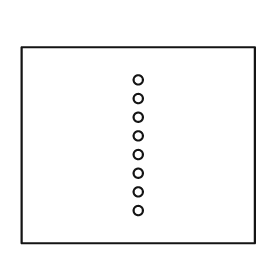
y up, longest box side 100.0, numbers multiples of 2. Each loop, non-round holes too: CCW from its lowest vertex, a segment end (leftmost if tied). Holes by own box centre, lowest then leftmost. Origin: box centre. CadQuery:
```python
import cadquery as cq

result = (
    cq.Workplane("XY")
    .moveTo(-50.0, -42.0)
    .lineTo(50.0, -42.0)
    .lineTo(50.0, 42.0)
    .lineTo(-50.0, 42.0)
    .close()
    .moveTo(0.0, -28.0)
    .circle(2.0)
    .moveTo(0.0, -20.0)
    .circle(2.0)
    .moveTo(0.0, -12.0)
    .circle(2.0)
    .moveTo(0.0, -4.0)
    .circle(2.0)
    .moveTo(0.0, 4.0)
    .circle(2.0)
    .moveTo(0.0, 12.0)
    .circle(2.0)
    .moveTo(0.0, 20.0)
    .circle(2.0)
    .moveTo(0.0, 28.0)
    .circle(2.0)
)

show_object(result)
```